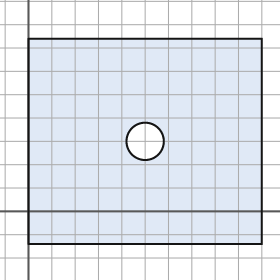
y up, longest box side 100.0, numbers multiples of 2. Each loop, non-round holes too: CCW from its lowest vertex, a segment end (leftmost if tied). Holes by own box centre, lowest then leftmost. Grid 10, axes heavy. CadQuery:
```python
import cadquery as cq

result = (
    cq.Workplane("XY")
    .moveTo(0.0, -14.0)
    .lineTo(100.0, -14.0)
    .lineTo(100.0, 74.0)
    .lineTo(0.0, 74.0)
    .close()
    .moveTo(50.0, 30.0)
    .circle(8.0)
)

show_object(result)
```